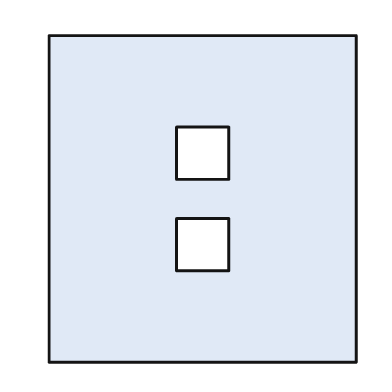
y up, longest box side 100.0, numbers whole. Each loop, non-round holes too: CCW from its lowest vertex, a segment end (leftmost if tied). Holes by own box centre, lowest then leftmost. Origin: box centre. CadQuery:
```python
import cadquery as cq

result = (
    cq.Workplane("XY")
    .moveTo(-47.0, -50.0)
    .lineTo(47.0, -50.0)
    .lineTo(47.0, 50.0)
    .lineTo(-47.0, 50.0)
    .close()
    .moveTo(-8.0, -22.0)
    .lineTo(8.0, -22.0)
    .lineTo(8.0, -6.0)
    .lineTo(-8.0, -6.0)
    .close()
    .moveTo(-8.0, 6.0)
    .lineTo(8.0, 6.0)
    .lineTo(8.0, 22.0)
    .lineTo(-8.0, 22.0)
    .close()
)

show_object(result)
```